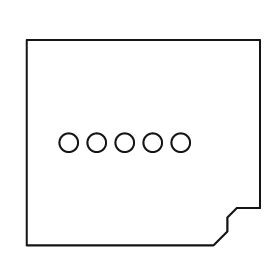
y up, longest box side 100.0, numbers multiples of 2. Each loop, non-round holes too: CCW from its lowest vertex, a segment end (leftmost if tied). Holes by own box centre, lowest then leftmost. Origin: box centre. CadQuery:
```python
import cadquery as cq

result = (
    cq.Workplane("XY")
    .moveTo(-50.0, -44.0)
    .lineTo(30.0, -44.0)
    .lineTo(36.0, -38.0)
    .lineTo(36.0, -32.0)
    .lineTo(40.0, -28.0)
    .lineTo(50.0, -28.0)
    .lineTo(50.0, 44.0)
    .lineTo(-50.0, 44.0)
    .close()
    .moveTo(-32.0, 0.0)
    .circle(4.0)
    .moveTo(-20.0, 0.0)
    .circle(4.0)
    .moveTo(-8.0, 0.0)
    .circle(4.0)
    .moveTo(4.0, 0.0)
    .circle(4.0)
    .moveTo(16.0, 0.0)
    .circle(4.0)
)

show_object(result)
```